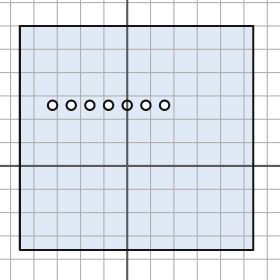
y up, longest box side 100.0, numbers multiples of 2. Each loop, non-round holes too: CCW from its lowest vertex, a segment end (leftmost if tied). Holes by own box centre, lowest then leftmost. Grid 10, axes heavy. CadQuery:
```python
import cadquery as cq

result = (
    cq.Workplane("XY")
    .moveTo(-46.0, -36.0)
    .lineTo(54.0, -36.0)
    .lineTo(54.0, 60.0)
    .lineTo(-46.0, 60.0)
    .close()
    .moveTo(-32.0, 26.0)
    .circle(2.0)
    .moveTo(-24.0, 26.0)
    .circle(2.0)
    .moveTo(-16.0, 26.0)
    .circle(2.0)
    .moveTo(-8.0, 26.0)
    .circle(2.0)
    .moveTo(0.0, 26.0)
    .circle(2.0)
    .moveTo(8.0, 26.0)
    .circle(2.0)
    .moveTo(16.0, 26.0)
    .circle(2.0)
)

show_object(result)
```